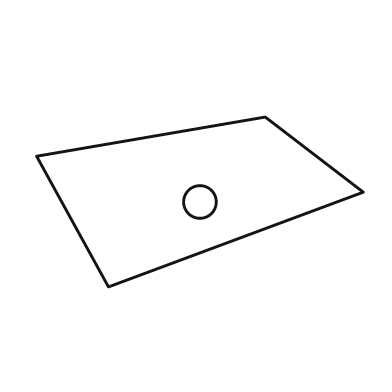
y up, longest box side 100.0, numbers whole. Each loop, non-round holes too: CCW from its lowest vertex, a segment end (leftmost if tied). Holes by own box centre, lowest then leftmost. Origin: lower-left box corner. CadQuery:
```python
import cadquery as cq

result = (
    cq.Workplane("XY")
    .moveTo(22.0, 0.0)
    .lineTo(100.0, 29.0)
    .lineTo(70.0, 52.0)
    .lineTo(0.0, 40.0)
    .close()
    .moveTo(50.0, 26.0)
    .circle(5.0)
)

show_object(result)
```